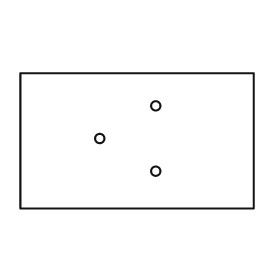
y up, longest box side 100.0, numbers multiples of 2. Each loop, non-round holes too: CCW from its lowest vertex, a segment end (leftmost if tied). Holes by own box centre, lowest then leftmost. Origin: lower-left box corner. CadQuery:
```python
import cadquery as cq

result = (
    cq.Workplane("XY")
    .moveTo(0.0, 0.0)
    .lineTo(100.0, 0.0)
    .lineTo(100.0, 58.0)
    .lineTo(0.0, 58.0)
    .close()
    .moveTo(58.0, 16.0)
    .circle(2.0)
    .moveTo(34.0, 30.0)
    .circle(2.0)
    .moveTo(58.0, 44.0)
    .circle(2.0)
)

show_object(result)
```